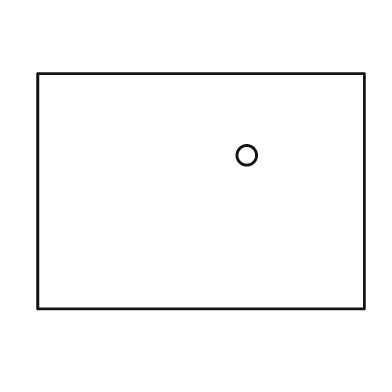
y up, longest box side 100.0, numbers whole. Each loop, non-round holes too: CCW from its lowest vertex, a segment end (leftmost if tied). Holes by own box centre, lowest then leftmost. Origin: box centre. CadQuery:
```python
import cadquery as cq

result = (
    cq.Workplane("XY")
    .moveTo(-50.0, -36.0)
    .lineTo(50.0, -36.0)
    .lineTo(50.0, 36.0)
    .lineTo(-50.0, 36.0)
    .close()
    .moveTo(14.0, 11.0)
    .circle(3.0)
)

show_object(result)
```